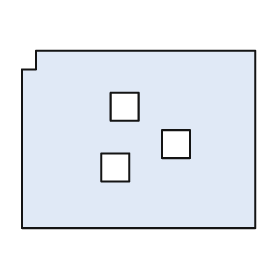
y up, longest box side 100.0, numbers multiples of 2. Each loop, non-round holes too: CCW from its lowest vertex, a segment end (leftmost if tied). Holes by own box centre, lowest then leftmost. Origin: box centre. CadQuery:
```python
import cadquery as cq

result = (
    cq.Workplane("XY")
    .moveTo(-50.0, -38.0)
    .lineTo(50.0, -38.0)
    .lineTo(50.0, 38.0)
    .lineTo(-44.0, 38.0)
    .lineTo(-44.0, 30.0)
    .lineTo(-50.0, 30.0)
    .close()
    .moveTo(-16.0, -18.0)
    .lineTo(-4.0, -18.0)
    .lineTo(-4.0, -6.0)
    .lineTo(-16.0, -6.0)
    .close()
    .moveTo(10.0, -8.0)
    .lineTo(22.0, -8.0)
    .lineTo(22.0, 4.0)
    .lineTo(10.0, 4.0)
    .close()
    .moveTo(-12.0, 8.0)
    .lineTo(0.0, 8.0)
    .lineTo(0.0, 20.0)
    .lineTo(-12.0, 20.0)
    .close()
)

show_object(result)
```